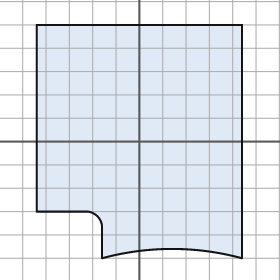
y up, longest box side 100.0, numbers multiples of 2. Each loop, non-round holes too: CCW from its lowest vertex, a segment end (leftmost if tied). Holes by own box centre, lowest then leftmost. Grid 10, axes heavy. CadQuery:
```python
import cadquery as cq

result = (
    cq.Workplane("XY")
    .moveTo(-16.0, -50.0)
    .threePointArc((14.0, -46.0), (44.0, -50.0))
    .lineTo(44.0, 50.0)
    .lineTo(-44.0, 50.0)
    .lineTo(-44.0, -30.0)
    .lineTo(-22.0, -30.0)
    .threePointArc((-18.0, -32.0), (-16.0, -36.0))
    .close()
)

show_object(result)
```